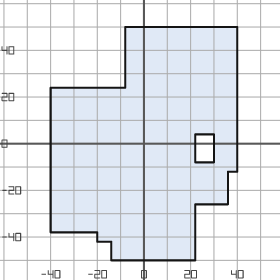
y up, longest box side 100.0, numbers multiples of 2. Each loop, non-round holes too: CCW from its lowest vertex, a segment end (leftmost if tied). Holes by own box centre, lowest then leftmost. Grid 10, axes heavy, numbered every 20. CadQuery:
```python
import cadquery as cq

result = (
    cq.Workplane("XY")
    .moveTo(-14.0, -50.0)
    .lineTo(22.0, -50.0)
    .lineTo(22.0, -26.0)
    .lineTo(36.0, -26.0)
    .lineTo(36.0, -12.0)
    .lineTo(40.0, -12.0)
    .lineTo(40.0, 50.0)
    .lineTo(-8.0, 50.0)
    .lineTo(-8.0, 24.0)
    .lineTo(-40.0, 24.0)
    .lineTo(-40.0, -38.0)
    .lineTo(-20.0, -38.0)
    .lineTo(-20.0, -42.0)
    .lineTo(-14.0, -42.0)
    .close()
    .moveTo(22.0, -8.0)
    .lineTo(30.0, -8.0)
    .lineTo(30.0, 4.0)
    .lineTo(22.0, 4.0)
    .close()
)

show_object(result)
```